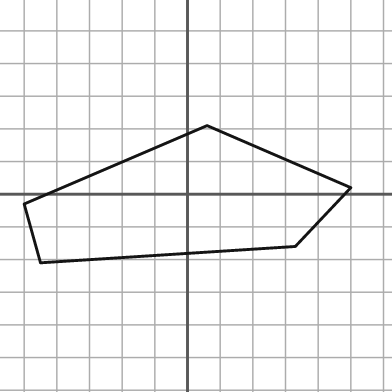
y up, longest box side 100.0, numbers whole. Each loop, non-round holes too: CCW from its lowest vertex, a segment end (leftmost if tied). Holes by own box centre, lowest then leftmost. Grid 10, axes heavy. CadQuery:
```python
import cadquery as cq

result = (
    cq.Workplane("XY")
    .moveTo(-45.0, -21.0)
    .lineTo(33.0, -16.0)
    .lineTo(50.0, 2.0)
    .lineTo(6.0, 21.0)
    .lineTo(-50.0, -3.0)
    .close()
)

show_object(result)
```